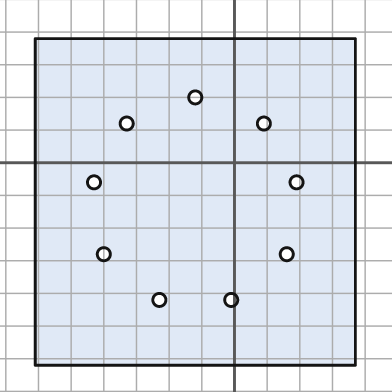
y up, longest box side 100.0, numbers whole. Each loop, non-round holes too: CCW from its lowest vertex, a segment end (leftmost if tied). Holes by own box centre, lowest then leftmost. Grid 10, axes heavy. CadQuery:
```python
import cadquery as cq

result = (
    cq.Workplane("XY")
    .moveTo(-61.0, -62.0)
    .lineTo(37.0, -62.0)
    .lineTo(37.0, 38.0)
    .lineTo(-61.0, 38.0)
    .close()
    .moveTo(-23.0, -42.0)
    .circle(2.0)
    .moveTo(-1.0, -42.0)
    .circle(2.0)
    .moveTo(-40.0, -28.0)
    .circle(2.0)
    .moveTo(16.0, -28.0)
    .circle(2.0)
    .moveTo(-43.0, -6.0)
    .circle(2.0)
    .moveTo(19.0, -6.0)
    .circle(2.0)
    .moveTo(-33.0, 12.0)
    .circle(2.0)
    .moveTo(9.0, 12.0)
    .circle(2.0)
    .moveTo(-12.0, 20.0)
    .circle(2.0)
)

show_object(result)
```